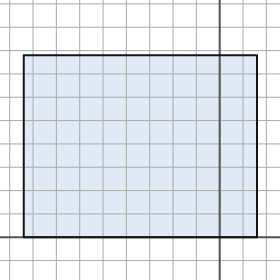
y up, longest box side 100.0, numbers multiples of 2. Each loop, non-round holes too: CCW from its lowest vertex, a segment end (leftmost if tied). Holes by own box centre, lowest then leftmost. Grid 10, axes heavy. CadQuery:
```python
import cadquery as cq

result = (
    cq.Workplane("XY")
    .moveTo(-84.0, 0.0)
    .lineTo(16.0, 0.0)
    .lineTo(16.0, 78.0)
    .lineTo(-84.0, 78.0)
    .close()
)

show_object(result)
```